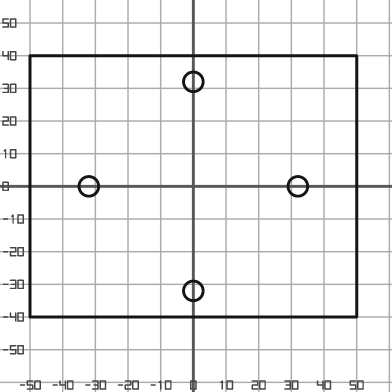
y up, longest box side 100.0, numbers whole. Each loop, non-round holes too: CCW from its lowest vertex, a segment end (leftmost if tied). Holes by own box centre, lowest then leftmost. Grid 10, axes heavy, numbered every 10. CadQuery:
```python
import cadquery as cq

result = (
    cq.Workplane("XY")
    .moveTo(-50.0, -40.0)
    .lineTo(50.0, -40.0)
    .lineTo(50.0, 40.0)
    .lineTo(-50.0, 40.0)
    .close()
    .moveTo(0.0, -32.0)
    .circle(3.0)
    .moveTo(-32.0, 0.0)
    .circle(3.0)
    .moveTo(32.0, 0.0)
    .circle(3.0)
    .moveTo(0.0, 32.0)
    .circle(3.0)
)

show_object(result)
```